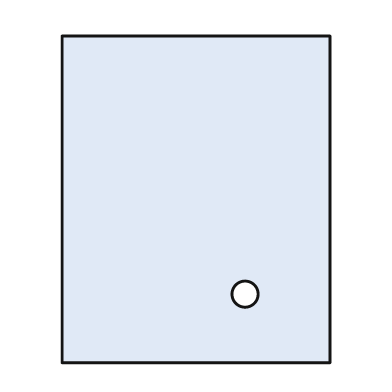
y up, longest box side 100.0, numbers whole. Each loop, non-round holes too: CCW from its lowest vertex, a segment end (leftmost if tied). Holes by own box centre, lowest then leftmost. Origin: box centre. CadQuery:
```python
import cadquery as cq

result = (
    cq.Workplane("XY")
    .moveTo(-41.0, -50.0)
    .lineTo(41.0, -50.0)
    .lineTo(41.0, 50.0)
    .lineTo(-41.0, 50.0)
    .close()
    .moveTo(15.0, -29.0)
    .circle(4.0)
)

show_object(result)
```